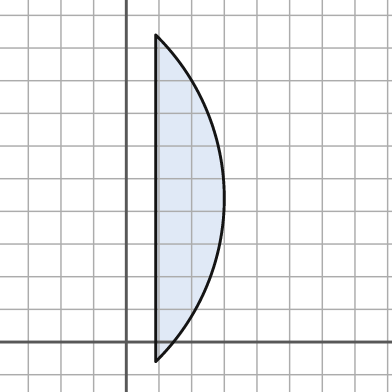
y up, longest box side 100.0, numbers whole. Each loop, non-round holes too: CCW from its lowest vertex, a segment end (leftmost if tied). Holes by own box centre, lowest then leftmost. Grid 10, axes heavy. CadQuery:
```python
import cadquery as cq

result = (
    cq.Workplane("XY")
    .moveTo(9.0, -6.0)
    .threePointArc((30.0, 44.0), (9.0, 94.0))
    .close()
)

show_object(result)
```